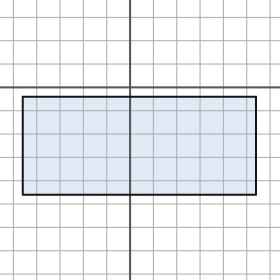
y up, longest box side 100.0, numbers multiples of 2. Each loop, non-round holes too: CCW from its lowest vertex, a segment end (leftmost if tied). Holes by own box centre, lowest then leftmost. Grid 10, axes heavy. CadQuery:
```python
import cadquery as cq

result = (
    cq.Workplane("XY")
    .moveTo(-46.0, -46.0)
    .lineTo(54.0, -46.0)
    .lineTo(54.0, -4.0)
    .lineTo(-46.0, -4.0)
    .close()
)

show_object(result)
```